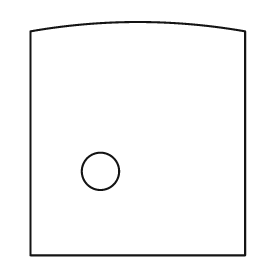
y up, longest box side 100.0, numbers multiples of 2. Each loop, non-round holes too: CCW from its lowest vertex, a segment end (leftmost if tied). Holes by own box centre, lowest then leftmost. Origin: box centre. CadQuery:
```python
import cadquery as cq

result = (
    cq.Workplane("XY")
    .moveTo(-46.0, -50.0)
    .lineTo(46.0, -50.0)
    .lineTo(46.0, 46.0)
    .threePointArc((0.0, 50.0), (-46.0, 46.0))
    .close()
    .moveTo(-16.0, -14.0)
    .circle(8.0)
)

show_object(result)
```